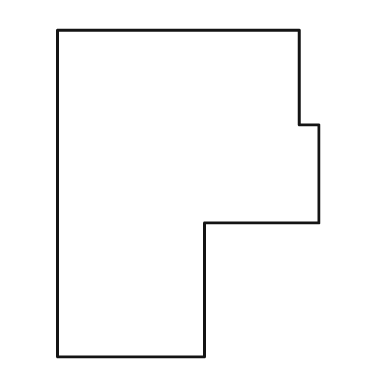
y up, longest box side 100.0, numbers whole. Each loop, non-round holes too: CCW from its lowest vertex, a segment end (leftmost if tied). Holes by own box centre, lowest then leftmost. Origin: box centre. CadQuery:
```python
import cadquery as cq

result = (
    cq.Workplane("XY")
    .moveTo(-40.0, -50.0)
    .lineTo(5.0, -50.0)
    .lineTo(5.0, -9.0)
    .lineTo(40.0, -9.0)
    .lineTo(40.0, 21.0)
    .lineTo(34.0, 21.0)
    .lineTo(34.0, 50.0)
    .lineTo(-40.0, 50.0)
    .close()
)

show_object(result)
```